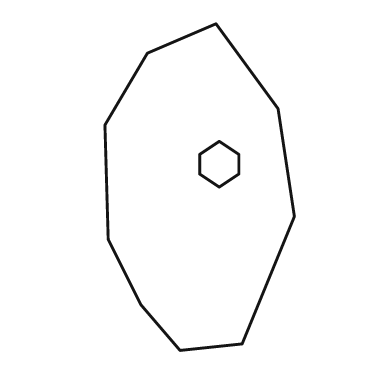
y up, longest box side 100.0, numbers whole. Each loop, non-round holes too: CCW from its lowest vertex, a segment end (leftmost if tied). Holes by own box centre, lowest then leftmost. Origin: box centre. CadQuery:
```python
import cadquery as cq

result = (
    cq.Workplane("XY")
    .moveTo(-6.0, -50.0)
    .lineTo(13.0, -48.0)
    .lineTo(29.0, -9.0)
    .lineTo(24.0, 24.0)
    .lineTo(5.0, 50.0)
    .lineTo(-16.0, 41.0)
    .lineTo(-29.0, 19.0)
    .lineTo(-28.0, -16.0)
    .lineTo(-18.0, -36.0)
    .close()
    .moveTo(6.0, 0.0)
    .lineTo(12.0, 4.0)
    .lineTo(12.0, 10.0)
    .lineTo(6.0, 14.0)
    .lineTo(0.0, 10.0)
    .lineTo(0.0, 4.0)
    .close()
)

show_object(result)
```